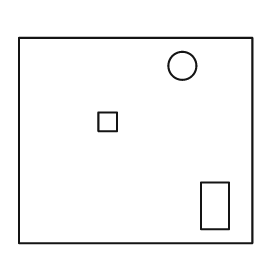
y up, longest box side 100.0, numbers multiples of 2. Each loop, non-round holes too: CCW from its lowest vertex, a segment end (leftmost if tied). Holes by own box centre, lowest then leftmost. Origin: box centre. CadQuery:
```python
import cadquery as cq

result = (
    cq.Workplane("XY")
    .moveTo(-50.0, -44.0)
    .lineTo(50.0, -44.0)
    .lineTo(50.0, 44.0)
    .lineTo(-50.0, 44.0)
    .close()
    .moveTo(28.0, -38.0)
    .lineTo(40.0, -38.0)
    .lineTo(40.0, -18.0)
    .lineTo(28.0, -18.0)
    .close()
    .moveTo(-16.0, 4.0)
    .lineTo(-8.0, 4.0)
    .lineTo(-8.0, 12.0)
    .lineTo(-16.0, 12.0)
    .close()
    .moveTo(20.0, 32.0)
    .circle(6.0)
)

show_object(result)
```